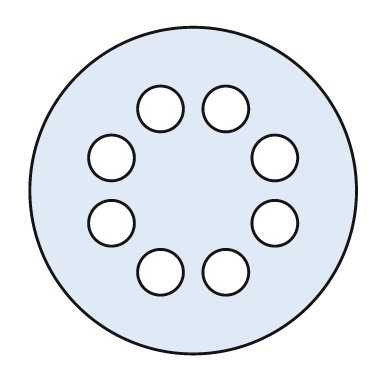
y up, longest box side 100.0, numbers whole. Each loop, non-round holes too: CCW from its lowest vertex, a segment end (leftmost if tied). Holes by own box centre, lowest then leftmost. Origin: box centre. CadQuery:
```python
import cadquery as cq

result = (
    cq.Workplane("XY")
    .moveTo(0.0, 0.0)
    .circle(50.0)
    .moveTo(-10.0, -25.0)
    .circle(7.0)
    .moveTo(10.0, -25.0)
    .circle(7.0)
    .moveTo(-25.0, -10.0)
    .circle(7.0)
    .moveTo(25.0, -10.0)
    .circle(7.0)
    .moveTo(-25.0, 10.0)
    .circle(7.0)
    .moveTo(25.0, 10.0)
    .circle(7.0)
    .moveTo(-10.0, 25.0)
    .circle(7.0)
    .moveTo(10.0, 25.0)
    .circle(7.0)
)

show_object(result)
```